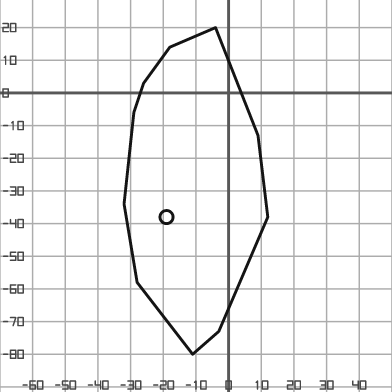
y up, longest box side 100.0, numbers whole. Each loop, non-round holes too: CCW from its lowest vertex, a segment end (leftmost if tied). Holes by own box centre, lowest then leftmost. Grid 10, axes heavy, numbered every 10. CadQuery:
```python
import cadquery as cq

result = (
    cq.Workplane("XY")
    .moveTo(-11.0, -80.0)
    .lineTo(-3.0, -73.0)
    .lineTo(12.0, -38.0)
    .lineTo(9.0, -13.0)
    .lineTo(-4.0, 20.0)
    .lineTo(-18.0, 14.0)
    .lineTo(-26.0, 3.0)
    .lineTo(-29.0, -6.0)
    .lineTo(-32.0, -34.0)
    .lineTo(-28.0, -58.0)
    .close()
    .moveTo(-19.0, -38.0)
    .circle(2.0)
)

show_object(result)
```